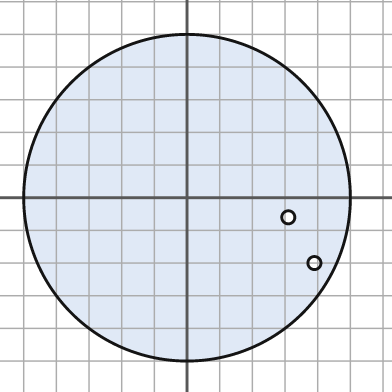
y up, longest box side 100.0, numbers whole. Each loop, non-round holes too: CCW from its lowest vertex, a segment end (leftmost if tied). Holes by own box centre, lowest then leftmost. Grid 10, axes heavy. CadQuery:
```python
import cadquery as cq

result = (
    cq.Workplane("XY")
    .moveTo(0.0, 0.0)
    .circle(50.0)
    .moveTo(39.0, -20.0)
    .circle(2.0)
    .moveTo(31.0, -6.0)
    .circle(2.0)
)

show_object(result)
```